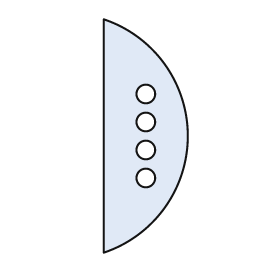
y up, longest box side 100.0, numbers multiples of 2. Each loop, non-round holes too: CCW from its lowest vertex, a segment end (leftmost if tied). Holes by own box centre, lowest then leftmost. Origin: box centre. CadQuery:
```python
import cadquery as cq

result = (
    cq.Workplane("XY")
    .moveTo(-18.0, -50.0)
    .threePointArc((18.0, 0.0), (-18.0, 50.0))
    .close()
    .moveTo(0.0, -18.0)
    .circle(4.0)
    .moveTo(0.0, -6.0)
    .circle(4.0)
    .moveTo(0.0, 6.0)
    .circle(4.0)
    .moveTo(0.0, 18.0)
    .circle(4.0)
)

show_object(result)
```